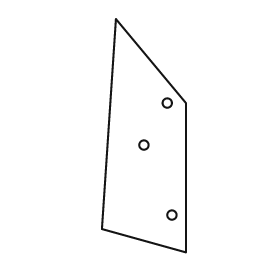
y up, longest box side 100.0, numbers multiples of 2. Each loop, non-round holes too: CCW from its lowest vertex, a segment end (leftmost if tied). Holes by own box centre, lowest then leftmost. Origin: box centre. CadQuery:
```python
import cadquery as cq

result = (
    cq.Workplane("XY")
    .moveTo(18.0, -50.0)
    .lineTo(18.0, 14.0)
    .lineTo(-12.0, 50.0)
    .lineTo(-18.0, -40.0)
    .close()
    .moveTo(12.0, -34.0)
    .circle(2.0)
    .moveTo(0.0, -4.0)
    .circle(2.0)
    .moveTo(10.0, 14.0)
    .circle(2.0)
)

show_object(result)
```